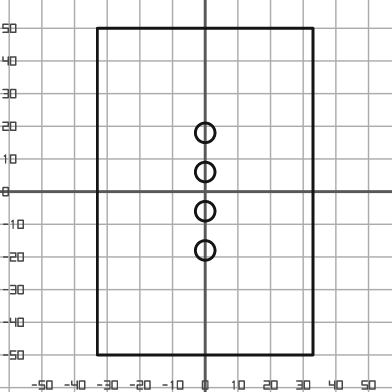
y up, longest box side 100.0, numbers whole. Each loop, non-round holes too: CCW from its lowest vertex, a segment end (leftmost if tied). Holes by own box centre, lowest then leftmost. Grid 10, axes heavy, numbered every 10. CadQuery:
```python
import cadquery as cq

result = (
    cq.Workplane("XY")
    .moveTo(-33.0, -50.0)
    .lineTo(33.0, -50.0)
    .lineTo(33.0, 50.0)
    .lineTo(-33.0, 50.0)
    .close()
    .moveTo(0.0, -18.0)
    .circle(3.0)
    .moveTo(0.0, -6.0)
    .circle(3.0)
    .moveTo(0.0, 6.0)
    .circle(3.0)
    .moveTo(0.0, 18.0)
    .circle(3.0)
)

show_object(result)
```